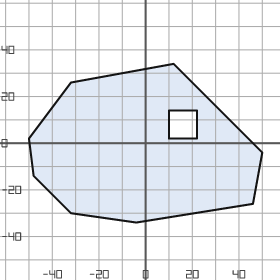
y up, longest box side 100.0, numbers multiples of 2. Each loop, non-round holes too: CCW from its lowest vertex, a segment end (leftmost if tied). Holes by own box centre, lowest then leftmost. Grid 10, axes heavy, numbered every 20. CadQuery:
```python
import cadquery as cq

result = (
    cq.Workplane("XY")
    .moveTo(-4.0, -34.0)
    .lineTo(46.0, -26.0)
    .lineTo(50.0, -4.0)
    .lineTo(12.0, 34.0)
    .lineTo(-32.0, 26.0)
    .lineTo(-50.0, 2.0)
    .lineTo(-48.0, -14.0)
    .lineTo(-32.0, -30.0)
    .close()
    .moveTo(10.0, 2.0)
    .lineTo(22.0, 2.0)
    .lineTo(22.0, 14.0)
    .lineTo(10.0, 14.0)
    .close()
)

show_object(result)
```